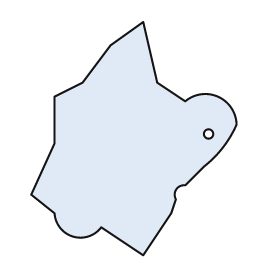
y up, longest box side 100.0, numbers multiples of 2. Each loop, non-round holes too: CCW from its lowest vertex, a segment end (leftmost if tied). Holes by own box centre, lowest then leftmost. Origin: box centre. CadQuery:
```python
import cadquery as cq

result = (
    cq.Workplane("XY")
    .moveTo(4.0, -50.0)
    .lineTo(16.0, -32.0)
    .lineTo(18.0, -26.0)
    .threePointArc((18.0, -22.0), (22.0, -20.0))
    .lineTo(30.0, -12.0)
    .threePointArc((38.0, -4.0), (44.0, 6.0))
    .threePointArc((36.0, 18.0), (22.0, 16.0))
    .lineTo(10.0, 24.0)
    .lineTo(4.0, 50.0)
    .lineTo(-10.0, 40.0)
    .lineTo(-22.0, 24.0)
    .lineTo(-34.0, 18.0)
    .lineTo(-34.0, -2.0)
    .lineTo(-44.0, -24.0)
    .lineTo(-34.0, -32.0)
    .threePointArc((-26.0, -42.0), (-14.0, -38.0))
    .close()
    .moveTo(32.0, 2.0)
    .circle(2.0)
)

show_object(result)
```